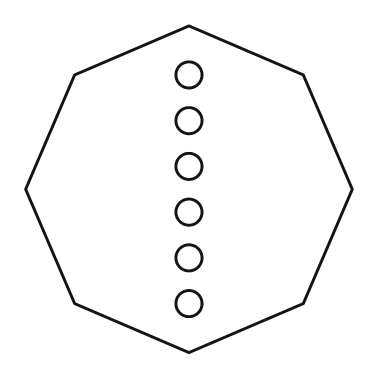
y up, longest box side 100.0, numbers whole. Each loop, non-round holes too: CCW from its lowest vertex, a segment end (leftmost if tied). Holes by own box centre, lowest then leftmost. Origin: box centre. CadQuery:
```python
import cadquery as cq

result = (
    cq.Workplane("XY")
    .moveTo(0.0, -50.0)
    .lineTo(35.0, -35.0)
    .lineTo(50.0, 0.0)
    .lineTo(35.0, 35.0)
    .lineTo(0.0, 50.0)
    .lineTo(-35.0, 35.0)
    .lineTo(-50.0, 0.0)
    .lineTo(-35.0, -35.0)
    .close()
    .moveTo(0.0, -35.0)
    .circle(4.0)
    .moveTo(0.0, -21.0)
    .circle(4.0)
    .moveTo(0.0, -7.0)
    .circle(4.0)
    .moveTo(0.0, 7.0)
    .circle(4.0)
    .moveTo(0.0, 21.0)
    .circle(4.0)
    .moveTo(0.0, 35.0)
    .circle(4.0)
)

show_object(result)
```